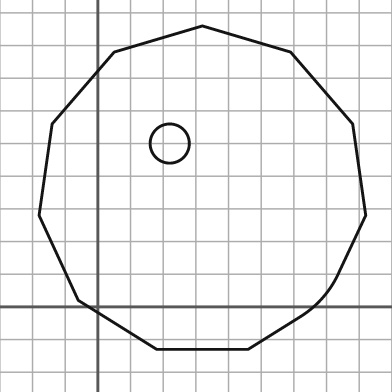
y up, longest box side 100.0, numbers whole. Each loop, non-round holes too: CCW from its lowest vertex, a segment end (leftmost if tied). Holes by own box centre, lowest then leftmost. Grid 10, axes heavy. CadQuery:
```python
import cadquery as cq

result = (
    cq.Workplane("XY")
    .moveTo(18.0, -13.0)
    .lineTo(46.0, -13.0)
    .lineTo(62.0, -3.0)
    .threePointArc((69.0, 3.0), (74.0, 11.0))
    .lineTo(82.0, 28.0)
    .lineTo(78.0, 56.0)
    .lineTo(59.0, 78.0)
    .lineTo(32.0, 86.0)
    .lineTo(5.0, 78.0)
    .lineTo(-14.0, 56.0)
    .lineTo(-18.0, 28.0)
    .lineTo(-6.0, 2.0)
    .close()
    .moveTo(22.0, 50.0)
    .circle(6.0)
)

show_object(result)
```